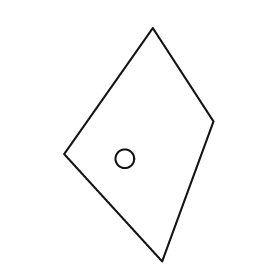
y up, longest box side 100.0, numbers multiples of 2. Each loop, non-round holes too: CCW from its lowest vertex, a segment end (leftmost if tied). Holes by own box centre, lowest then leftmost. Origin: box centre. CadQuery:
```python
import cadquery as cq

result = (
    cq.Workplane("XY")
    .moveTo(10.0, -50.0)
    .lineTo(32.0, 10.0)
    .lineTo(6.0, 50.0)
    .lineTo(-32.0, -4.0)
    .close()
    .moveTo(-6.0, -6.0)
    .circle(4.0)
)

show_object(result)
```